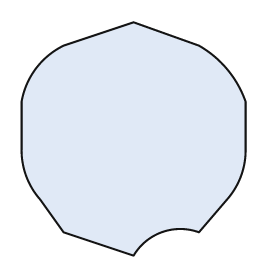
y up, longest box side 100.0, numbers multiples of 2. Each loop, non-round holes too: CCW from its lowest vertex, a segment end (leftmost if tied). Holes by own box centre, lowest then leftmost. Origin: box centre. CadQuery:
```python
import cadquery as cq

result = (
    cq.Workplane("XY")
    .moveTo(0.0, -50.0)
    .threePointArc((12.0, -40.0), (28.0, -40.0))
    .lineTo(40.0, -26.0)
    .threePointArc((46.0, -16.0), (48.0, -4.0))
    .lineTo(48.0, 16.0)
    .threePointArc((40.0, 30.0), (28.0, 40.0))
    .lineTo(0.0, 50.0)
    .lineTo(-30.0, 40.0)
    .threePointArc((-42.0, 30.0), (-48.0, 16.0))
    .lineTo(-48.0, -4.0)
    .threePointArc((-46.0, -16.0), (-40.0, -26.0))
    .lineTo(-30.0, -40.0)
    .close()
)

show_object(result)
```